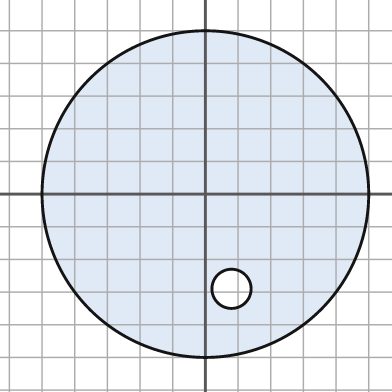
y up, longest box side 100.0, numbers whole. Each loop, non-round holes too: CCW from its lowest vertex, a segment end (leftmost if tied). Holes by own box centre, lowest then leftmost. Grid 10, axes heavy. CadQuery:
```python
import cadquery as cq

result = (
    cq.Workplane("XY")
    .moveTo(0.0, 0.0)
    .circle(50.0)
    .moveTo(8.0, -29.0)
    .circle(6.0)
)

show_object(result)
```